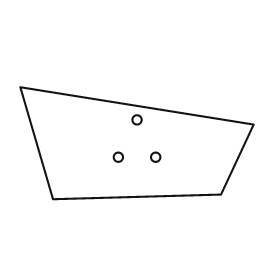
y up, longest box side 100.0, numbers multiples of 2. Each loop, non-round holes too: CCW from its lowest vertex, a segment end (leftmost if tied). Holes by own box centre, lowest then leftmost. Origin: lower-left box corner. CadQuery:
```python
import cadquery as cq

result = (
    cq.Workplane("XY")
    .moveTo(14.0, 0.0)
    .lineTo(86.0, 2.0)
    .lineTo(100.0, 32.0)
    .lineTo(0.0, 48.0)
    .close()
    .moveTo(42.0, 18.0)
    .circle(2.0)
    .moveTo(58.0, 18.0)
    .circle(2.0)
    .moveTo(50.0, 34.0)
    .circle(2.0)
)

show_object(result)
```